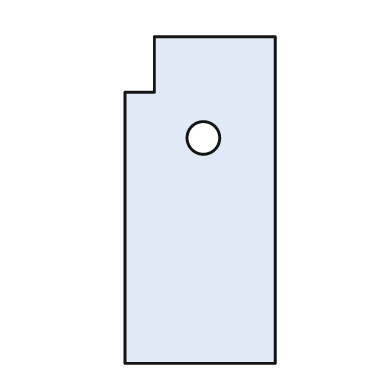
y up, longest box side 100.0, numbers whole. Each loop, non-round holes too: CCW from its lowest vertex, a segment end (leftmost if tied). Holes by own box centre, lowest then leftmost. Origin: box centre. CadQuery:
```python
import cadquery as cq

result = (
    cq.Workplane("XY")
    .moveTo(-23.0, -50.0)
    .lineTo(23.0, -50.0)
    .lineTo(23.0, 50.0)
    .lineTo(-14.0, 50.0)
    .lineTo(-14.0, 33.0)
    .lineTo(-23.0, 33.0)
    .close()
    .moveTo(1.0, 19.0)
    .circle(5.0)
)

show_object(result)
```